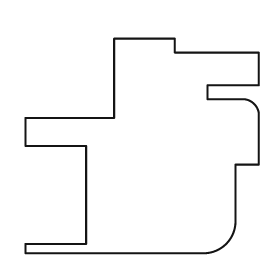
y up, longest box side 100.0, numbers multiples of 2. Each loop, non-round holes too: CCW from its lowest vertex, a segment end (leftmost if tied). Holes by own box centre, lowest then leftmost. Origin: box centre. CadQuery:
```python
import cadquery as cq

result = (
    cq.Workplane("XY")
    .moveTo(-50.0, -46.0)
    .lineTo(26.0, -46.0)
    .threePointArc((36.0, -42.0), (40.0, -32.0))
    .lineTo(40.0, -8.0)
    .lineTo(50.0, -8.0)
    .lineTo(50.0, 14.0)
    .threePointArc((48.0, 18.0), (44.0, 20.0))
    .lineTo(28.0, 20.0)
    .lineTo(28.0, 26.0)
    .lineTo(50.0, 26.0)
    .lineTo(50.0, 40.0)
    .lineTo(14.0, 40.0)
    .lineTo(14.0, 46.0)
    .lineTo(-12.0, 46.0)
    .lineTo(-12.0, 12.0)
    .lineTo(-50.0, 12.0)
    .lineTo(-50.0, 0.0)
    .lineTo(-24.0, 0.0)
    .lineTo(-24.0, -42.0)
    .lineTo(-50.0, -42.0)
    .close()
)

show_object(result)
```